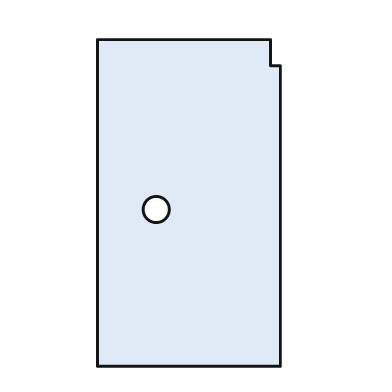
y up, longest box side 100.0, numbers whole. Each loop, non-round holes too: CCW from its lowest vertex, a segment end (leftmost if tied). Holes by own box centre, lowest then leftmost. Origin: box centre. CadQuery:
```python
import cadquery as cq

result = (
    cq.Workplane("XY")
    .moveTo(-28.0, -50.0)
    .lineTo(28.0, -50.0)
    .lineTo(28.0, 42.0)
    .lineTo(25.0, 42.0)
    .lineTo(25.0, 50.0)
    .lineTo(-28.0, 50.0)
    .close()
    .moveTo(-10.0, -2.0)
    .circle(4.0)
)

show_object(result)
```